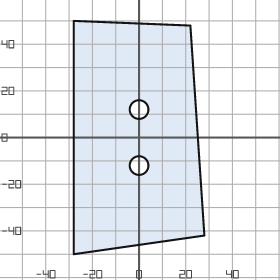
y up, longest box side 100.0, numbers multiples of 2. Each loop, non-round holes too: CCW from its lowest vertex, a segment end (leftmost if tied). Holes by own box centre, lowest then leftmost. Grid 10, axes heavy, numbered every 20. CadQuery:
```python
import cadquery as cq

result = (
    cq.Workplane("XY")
    .moveTo(-28.0, -50.0)
    .lineTo(28.0, -42.0)
    .lineTo(22.0, 48.0)
    .lineTo(-28.0, 50.0)
    .close()
    .moveTo(0.0, -12.0)
    .circle(4.0)
    .moveTo(0.0, 12.0)
    .circle(4.0)
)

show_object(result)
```